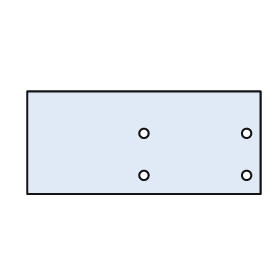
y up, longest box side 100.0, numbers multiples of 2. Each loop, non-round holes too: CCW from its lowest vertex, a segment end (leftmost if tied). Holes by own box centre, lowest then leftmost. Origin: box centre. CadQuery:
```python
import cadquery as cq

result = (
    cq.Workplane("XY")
    .moveTo(-50.0, -22.0)
    .lineTo(50.0, -22.0)
    .lineTo(50.0, 22.0)
    .lineTo(-50.0, 22.0)
    .close()
    .moveTo(0.0, -14.0)
    .circle(2.0)
    .moveTo(44.0, -14.0)
    .circle(2.0)
    .moveTo(0.0, 4.0)
    .circle(2.0)
    .moveTo(44.0, 4.0)
    .circle(2.0)
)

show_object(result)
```